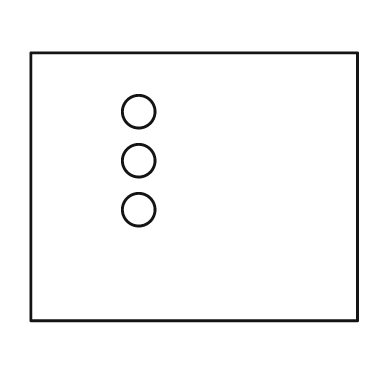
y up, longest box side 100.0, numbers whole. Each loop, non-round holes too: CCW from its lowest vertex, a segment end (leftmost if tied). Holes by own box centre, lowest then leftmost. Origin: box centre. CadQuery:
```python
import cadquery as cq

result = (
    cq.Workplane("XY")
    .moveTo(-50.0, -41.0)
    .lineTo(50.0, -41.0)
    .lineTo(50.0, 41.0)
    .lineTo(-50.0, 41.0)
    .close()
    .moveTo(-17.0, -7.0)
    .circle(5.0)
    .moveTo(-17.0, 8.0)
    .circle(5.0)
    .moveTo(-17.0, 23.0)
    .circle(5.0)
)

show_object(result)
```